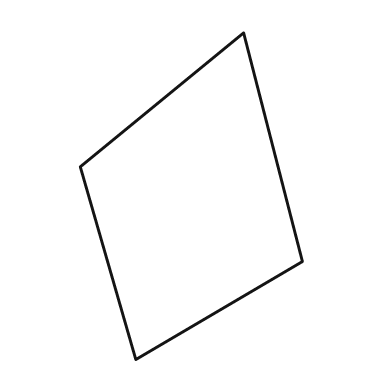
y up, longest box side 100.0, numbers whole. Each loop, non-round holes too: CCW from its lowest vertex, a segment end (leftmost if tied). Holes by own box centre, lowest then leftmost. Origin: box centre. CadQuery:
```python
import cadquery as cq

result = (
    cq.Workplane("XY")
    .moveTo(-17.0, -50.0)
    .lineTo(34.0, -20.0)
    .lineTo(16.0, 50.0)
    .lineTo(-34.0, 9.0)
    .close()
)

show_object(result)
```